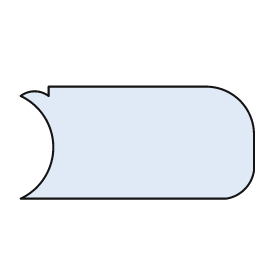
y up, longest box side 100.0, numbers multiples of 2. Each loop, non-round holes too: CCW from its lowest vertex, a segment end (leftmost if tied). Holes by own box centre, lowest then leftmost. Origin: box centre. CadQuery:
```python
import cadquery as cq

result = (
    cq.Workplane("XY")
    .moveTo(-50.0, -24.0)
    .lineTo(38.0, -24.0)
    .threePointArc((46.0, -20.0), (50.0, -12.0))
    .lineTo(50.0, 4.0)
    .threePointArc((44.0, 18.0), (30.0, 24.0))
    .lineTo(-38.0, 24.0)
    .lineTo(-38.0, 20.0)
    .threePointArc((-44.0, 22.0), (-50.0, 20.0))
    .threePointArc((-36.0, -2.0), (-50.0, -24.0))
    .close()
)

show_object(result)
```